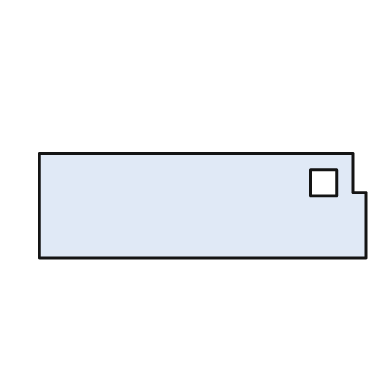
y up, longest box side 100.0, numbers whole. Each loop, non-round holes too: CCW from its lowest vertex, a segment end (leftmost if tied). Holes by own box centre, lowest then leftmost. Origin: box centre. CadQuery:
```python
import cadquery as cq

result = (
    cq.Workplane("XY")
    .moveTo(-50.0, -16.0)
    .lineTo(50.0, -16.0)
    .lineTo(50.0, 4.0)
    .lineTo(46.0, 4.0)
    .lineTo(46.0, 16.0)
    .lineTo(-50.0, 16.0)
    .close()
    .moveTo(33.0, 3.0)
    .lineTo(41.0, 3.0)
    .lineTo(41.0, 11.0)
    .lineTo(33.0, 11.0)
    .close()
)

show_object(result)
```